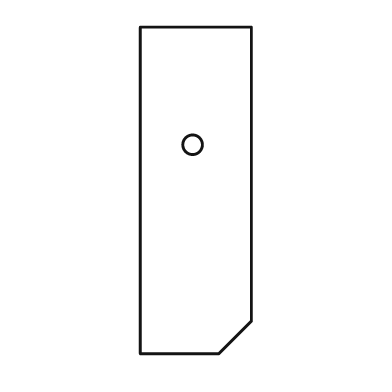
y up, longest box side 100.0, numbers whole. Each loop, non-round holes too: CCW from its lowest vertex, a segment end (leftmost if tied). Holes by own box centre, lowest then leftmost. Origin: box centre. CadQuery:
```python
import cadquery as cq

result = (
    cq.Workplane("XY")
    .moveTo(-17.0, -50.0)
    .lineTo(7.0, -50.0)
    .lineTo(17.0, -40.0)
    .lineTo(17.0, 50.0)
    .lineTo(-17.0, 50.0)
    .close()
    .moveTo(-1.0, 14.0)
    .circle(3.0)
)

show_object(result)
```